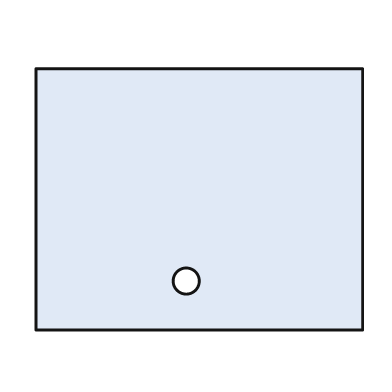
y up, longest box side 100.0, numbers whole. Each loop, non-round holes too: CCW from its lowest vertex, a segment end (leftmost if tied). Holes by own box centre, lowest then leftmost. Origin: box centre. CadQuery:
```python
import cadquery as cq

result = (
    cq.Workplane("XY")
    .moveTo(-50.0, -40.0)
    .lineTo(50.0, -40.0)
    .lineTo(50.0, 40.0)
    .lineTo(-50.0, 40.0)
    .close()
    .moveTo(-4.0, -25.0)
    .circle(4.0)
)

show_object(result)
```